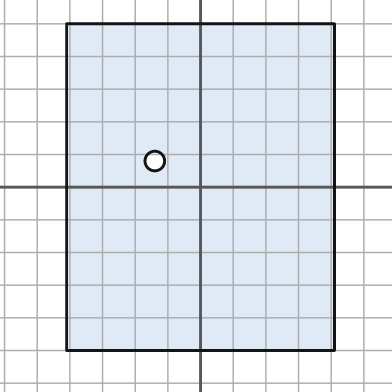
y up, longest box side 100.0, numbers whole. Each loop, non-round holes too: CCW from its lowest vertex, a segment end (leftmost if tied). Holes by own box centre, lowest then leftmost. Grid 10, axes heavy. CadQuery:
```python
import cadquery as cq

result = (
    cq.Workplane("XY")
    .moveTo(-41.0, -50.0)
    .lineTo(41.0, -50.0)
    .lineTo(41.0, 50.0)
    .lineTo(-41.0, 50.0)
    .close()
    .moveTo(-14.0, 8.0)
    .circle(3.0)
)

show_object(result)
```